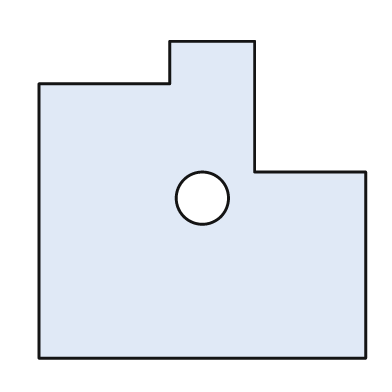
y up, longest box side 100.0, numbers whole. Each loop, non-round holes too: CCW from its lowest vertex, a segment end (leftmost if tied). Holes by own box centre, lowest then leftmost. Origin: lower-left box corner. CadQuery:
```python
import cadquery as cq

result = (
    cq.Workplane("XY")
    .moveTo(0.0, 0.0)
    .lineTo(100.0, 0.0)
    .lineTo(100.0, 57.0)
    .lineTo(66.0, 57.0)
    .lineTo(66.0, 97.0)
    .lineTo(40.0, 97.0)
    .lineTo(40.0, 84.0)
    .lineTo(0.0, 84.0)
    .close()
    .moveTo(50.0, 49.0)
    .circle(8.0)
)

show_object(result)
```